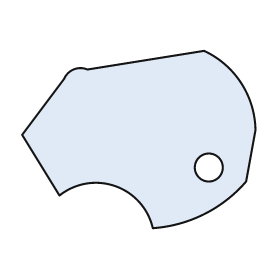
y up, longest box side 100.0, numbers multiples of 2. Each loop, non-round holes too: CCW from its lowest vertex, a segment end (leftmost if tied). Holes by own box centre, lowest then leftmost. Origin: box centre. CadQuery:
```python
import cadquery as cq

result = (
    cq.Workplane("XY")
    .moveTo(6.0, -38.0)
    .threePointArc((28.0, -32.0), (46.0, -18.0))
    .lineTo(50.0, 4.0)
    .threePointArc((44.0, 24.0), (28.0, 38.0))
    .lineTo(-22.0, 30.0)
    .threePointArc((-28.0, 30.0), (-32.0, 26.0))
    .lineTo(-50.0, 2.0)
    .lineTo(-34.0, -24.0)
    .threePointArc((-10.0, -20.0), (6.0, -38.0))
    .close()
    .moveTo(30.0, -12.0)
    .circle(6.0)
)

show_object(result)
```